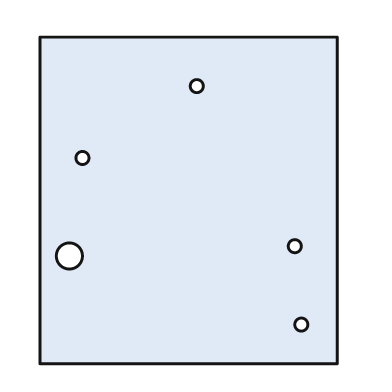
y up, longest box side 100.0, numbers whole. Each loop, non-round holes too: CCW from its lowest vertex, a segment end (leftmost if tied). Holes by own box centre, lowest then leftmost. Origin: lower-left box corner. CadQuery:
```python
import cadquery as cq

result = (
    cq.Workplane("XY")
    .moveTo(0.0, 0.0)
    .lineTo(91.0, 0.0)
    .lineTo(91.0, 100.0)
    .lineTo(0.0, 100.0)
    .close()
    .moveTo(80.0, 12.0)
    .circle(2.0)
    .moveTo(9.0, 33.0)
    .circle(4.0)
    .moveTo(78.0, 36.0)
    .circle(2.0)
    .moveTo(13.0, 63.0)
    .circle(2.0)
    .moveTo(48.0, 85.0)
    .circle(2.0)
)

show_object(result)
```